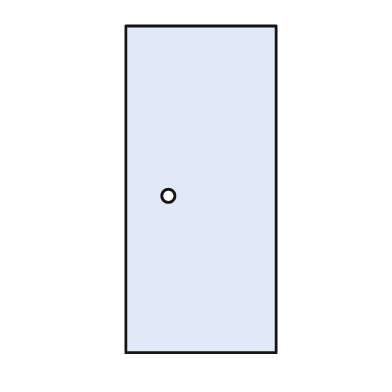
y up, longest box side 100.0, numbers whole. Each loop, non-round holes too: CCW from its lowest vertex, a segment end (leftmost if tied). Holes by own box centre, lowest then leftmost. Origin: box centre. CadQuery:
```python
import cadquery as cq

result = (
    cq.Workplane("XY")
    .moveTo(-23.0, -50.0)
    .lineTo(23.0, -50.0)
    .lineTo(23.0, 50.0)
    .lineTo(-23.0, 50.0)
    .close()
    .moveTo(-10.0, -2.0)
    .circle(2.0)
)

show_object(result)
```